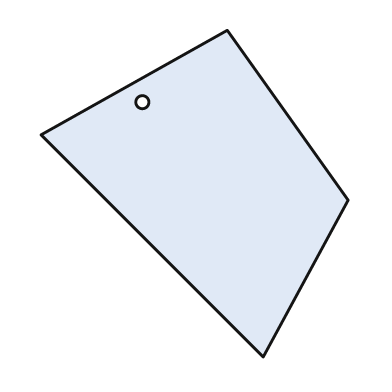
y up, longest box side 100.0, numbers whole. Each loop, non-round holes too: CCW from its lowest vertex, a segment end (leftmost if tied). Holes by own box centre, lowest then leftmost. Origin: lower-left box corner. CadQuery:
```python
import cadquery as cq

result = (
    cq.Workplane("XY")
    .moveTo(68.0, 0.0)
    .lineTo(94.0, 48.0)
    .lineTo(57.0, 100.0)
    .lineTo(0.0, 68.0)
    .close()
    .moveTo(31.0, 78.0)
    .circle(2.0)
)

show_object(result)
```